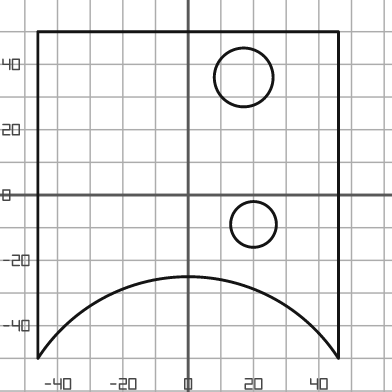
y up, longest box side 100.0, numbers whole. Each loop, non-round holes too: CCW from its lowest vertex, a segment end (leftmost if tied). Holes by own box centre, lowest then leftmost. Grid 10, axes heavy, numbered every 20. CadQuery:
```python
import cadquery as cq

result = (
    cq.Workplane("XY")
    .moveTo(-46.0, -50.0)
    .threePointArc((0.0, -25.0), (46.0, -50.0))
    .lineTo(46.0, 50.0)
    .lineTo(-46.0, 50.0)
    .close()
    .moveTo(20.0, -9.0)
    .circle(7.0)
    .moveTo(17.0, 36.0)
    .circle(9.0)
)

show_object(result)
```